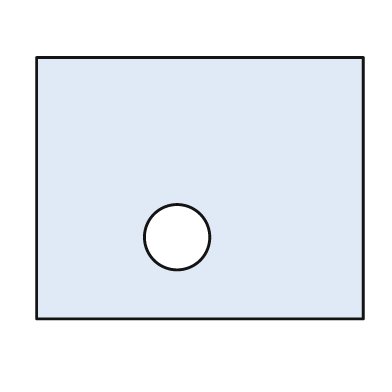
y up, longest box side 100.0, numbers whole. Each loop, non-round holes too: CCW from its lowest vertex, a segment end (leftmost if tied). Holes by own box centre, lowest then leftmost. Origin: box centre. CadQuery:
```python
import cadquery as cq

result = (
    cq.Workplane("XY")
    .moveTo(-50.0, -40.0)
    .lineTo(50.0, -40.0)
    .lineTo(50.0, 40.0)
    .lineTo(-50.0, 40.0)
    .close()
    .moveTo(-7.0, -15.0)
    .circle(10.0)
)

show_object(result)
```